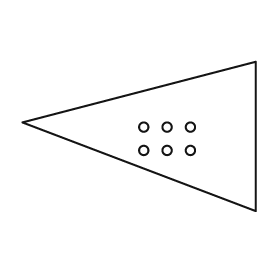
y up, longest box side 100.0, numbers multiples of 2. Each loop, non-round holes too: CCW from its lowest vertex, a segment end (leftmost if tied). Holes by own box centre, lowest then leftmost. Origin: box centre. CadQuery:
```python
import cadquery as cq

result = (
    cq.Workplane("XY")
    .moveTo(50.0, -32.0)
    .lineTo(50.0, 32.0)
    .lineTo(-50.0, 6.0)
    .close()
    .moveTo(2.0, -6.0)
    .circle(2.0)
    .moveTo(12.0, -6.0)
    .circle(2.0)
    .moveTo(22.0, -6.0)
    .circle(2.0)
    .moveTo(2.0, 4.0)
    .circle(2.0)
    .moveTo(12.0, 4.0)
    .circle(2.0)
    .moveTo(22.0, 4.0)
    .circle(2.0)
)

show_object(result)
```